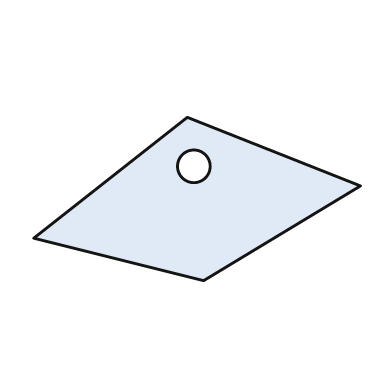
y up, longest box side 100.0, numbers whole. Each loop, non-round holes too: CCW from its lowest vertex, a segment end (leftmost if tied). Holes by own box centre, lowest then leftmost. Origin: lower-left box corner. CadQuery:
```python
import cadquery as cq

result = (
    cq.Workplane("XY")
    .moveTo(52.0, 0.0)
    .lineTo(100.0, 29.0)
    .lineTo(47.0, 50.0)
    .lineTo(0.0, 13.0)
    .close()
    .moveTo(49.0, 35.0)
    .circle(5.0)
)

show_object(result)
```